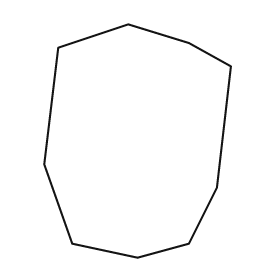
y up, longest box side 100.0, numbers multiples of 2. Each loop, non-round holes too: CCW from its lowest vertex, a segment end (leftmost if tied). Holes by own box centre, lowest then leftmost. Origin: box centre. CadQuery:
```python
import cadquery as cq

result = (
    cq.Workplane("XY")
    .moveTo(0.0, -50.0)
    .lineTo(22.0, -44.0)
    .lineTo(34.0, -20.0)
    .lineTo(40.0, 32.0)
    .lineTo(22.0, 42.0)
    .lineTo(-4.0, 50.0)
    .lineTo(-34.0, 40.0)
    .lineTo(-40.0, -10.0)
    .lineTo(-28.0, -44.0)
    .close()
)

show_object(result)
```